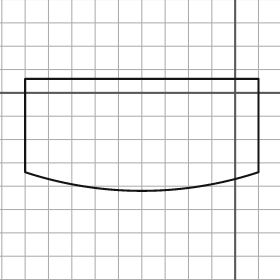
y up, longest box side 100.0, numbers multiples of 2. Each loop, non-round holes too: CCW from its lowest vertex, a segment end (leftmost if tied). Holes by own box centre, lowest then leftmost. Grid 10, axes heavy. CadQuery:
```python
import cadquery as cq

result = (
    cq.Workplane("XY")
    .moveTo(-90.0, -34.0)
    .threePointArc((-40.0, -42.0), (10.0, -34.0))
    .lineTo(10.0, 6.0)
    .lineTo(-90.0, 6.0)
    .close()
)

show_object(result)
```